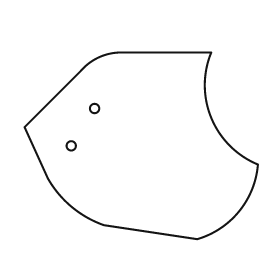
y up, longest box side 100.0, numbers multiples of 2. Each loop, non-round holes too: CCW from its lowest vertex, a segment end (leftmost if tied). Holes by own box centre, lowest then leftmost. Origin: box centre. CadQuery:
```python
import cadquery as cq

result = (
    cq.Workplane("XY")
    .moveTo(24.0, -40.0)
    .threePointArc((42.0, -28.0), (50.0, -8.0))
    .threePointArc((30.0, 12.0), (30.0, 40.0))
    .lineTo(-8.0, 40.0)
    .threePointArc((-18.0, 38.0), (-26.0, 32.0))
    .lineTo(-50.0, 8.0)
    .lineTo(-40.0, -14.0)
    .threePointArc((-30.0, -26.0), (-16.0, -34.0))
    .close()
    .moveTo(-30.0, 0.0)
    .circle(2.0)
    .moveTo(-20.0, 16.0)
    .circle(2.0)
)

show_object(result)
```